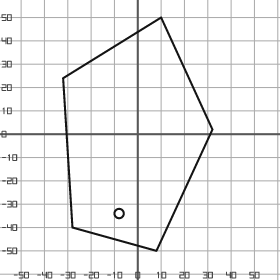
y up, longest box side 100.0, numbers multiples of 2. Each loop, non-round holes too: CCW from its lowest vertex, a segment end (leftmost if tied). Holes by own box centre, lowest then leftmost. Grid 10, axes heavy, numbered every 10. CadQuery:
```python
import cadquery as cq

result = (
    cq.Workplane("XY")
    .moveTo(8.0, -50.0)
    .lineTo(32.0, 2.0)
    .lineTo(10.0, 50.0)
    .lineTo(-32.0, 24.0)
    .lineTo(-28.0, -40.0)
    .close()
    .moveTo(-8.0, -34.0)
    .circle(2.0)
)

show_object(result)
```